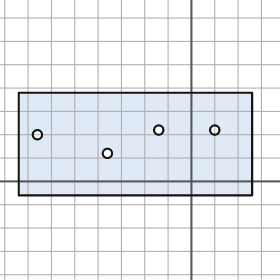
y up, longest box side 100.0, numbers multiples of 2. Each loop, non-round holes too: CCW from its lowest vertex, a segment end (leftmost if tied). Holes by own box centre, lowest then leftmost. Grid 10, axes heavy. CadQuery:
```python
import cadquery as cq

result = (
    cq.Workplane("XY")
    .moveTo(-74.0, -6.0)
    .lineTo(26.0, -6.0)
    .lineTo(26.0, 38.0)
    .lineTo(-74.0, 38.0)
    .close()
    .moveTo(-36.0, 12.0)
    .circle(2.0)
    .moveTo(-66.0, 20.0)
    .circle(2.0)
    .moveTo(-14.0, 22.0)
    .circle(2.0)
    .moveTo(10.0, 22.0)
    .circle(2.0)
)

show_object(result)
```